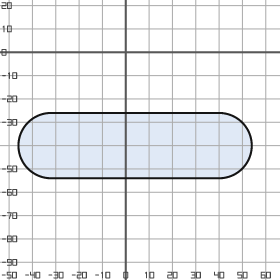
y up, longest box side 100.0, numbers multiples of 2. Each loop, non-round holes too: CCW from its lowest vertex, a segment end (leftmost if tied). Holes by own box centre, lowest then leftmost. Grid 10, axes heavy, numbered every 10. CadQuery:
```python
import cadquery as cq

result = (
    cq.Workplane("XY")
    .moveTo(-32.0, -54.0)
    .lineTo(40.0, -54.0)
    .threePointArc((54.0, -40.0), (40.0, -26.0))
    .lineTo(-32.0, -26.0)
    .threePointArc((-46.0, -40.0), (-32.0, -54.0))
    .close()
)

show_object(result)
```